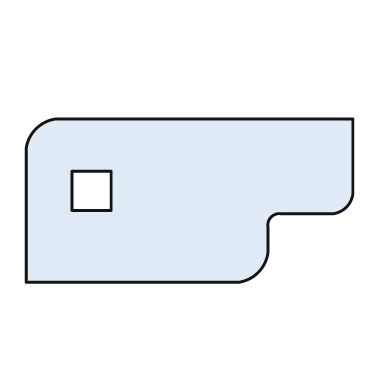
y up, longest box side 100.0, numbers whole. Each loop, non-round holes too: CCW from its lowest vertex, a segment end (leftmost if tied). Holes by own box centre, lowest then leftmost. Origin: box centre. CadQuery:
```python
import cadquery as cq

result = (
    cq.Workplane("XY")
    .moveTo(-50.0, -25.0)
    .lineTo(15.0, -25.0)
    .threePointArc((21.0, -22.0), (24.0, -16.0))
    .lineTo(24.0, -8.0)
    .threePointArc((25.0, -5.0), (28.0, -4.0))
    .lineTo(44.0, -4.0)
    .threePointArc((48.0, -2.0), (50.0, 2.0))
    .lineTo(50.0, 25.0)
    .lineTo(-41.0, 25.0)
    .threePointArc((-47.0, 22.0), (-50.0, 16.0))
    .close()
    .moveTo(-36.0, -3.0)
    .lineTo(-24.0, -3.0)
    .lineTo(-24.0, 9.0)
    .lineTo(-36.0, 9.0)
    .close()
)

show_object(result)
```